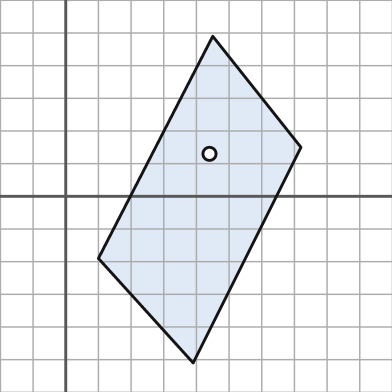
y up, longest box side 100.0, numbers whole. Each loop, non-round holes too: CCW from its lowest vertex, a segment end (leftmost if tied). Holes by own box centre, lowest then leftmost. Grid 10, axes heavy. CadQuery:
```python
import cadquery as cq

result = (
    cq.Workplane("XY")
    .moveTo(39.0, -51.0)
    .lineTo(72.0, 15.0)
    .lineTo(45.0, 49.0)
    .lineTo(10.0, -19.0)
    .close()
    .moveTo(44.0, 13.0)
    .circle(2.0)
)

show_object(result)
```